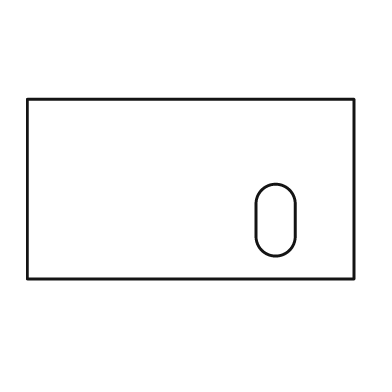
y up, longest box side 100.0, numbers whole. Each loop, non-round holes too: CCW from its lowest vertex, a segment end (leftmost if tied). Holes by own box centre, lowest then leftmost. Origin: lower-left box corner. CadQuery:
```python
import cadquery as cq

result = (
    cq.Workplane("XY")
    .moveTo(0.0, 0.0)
    .lineTo(100.0, 0.0)
    .lineTo(100.0, 55.0)
    .lineTo(0.0, 55.0)
    .close()
    .moveTo(70.0, 13.0)
    .threePointArc((76.0, 7.0), (82.0, 13.0))
    .lineTo(82.0, 23.0)
    .threePointArc((76.0, 29.0), (70.0, 23.0))
    .close()
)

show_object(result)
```